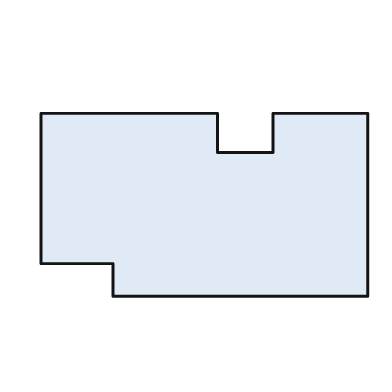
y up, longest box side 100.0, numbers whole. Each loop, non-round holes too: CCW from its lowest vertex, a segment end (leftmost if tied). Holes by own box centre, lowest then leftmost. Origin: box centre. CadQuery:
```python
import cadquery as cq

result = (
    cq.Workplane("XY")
    .moveTo(-28.0, -28.0)
    .lineTo(50.0, -28.0)
    .lineTo(50.0, 28.0)
    .lineTo(21.0, 28.0)
    .lineTo(21.0, 16.0)
    .lineTo(4.0, 16.0)
    .lineTo(4.0, 28.0)
    .lineTo(-50.0, 28.0)
    .lineTo(-50.0, -18.0)
    .lineTo(-28.0, -18.0)
    .close()
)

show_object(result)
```